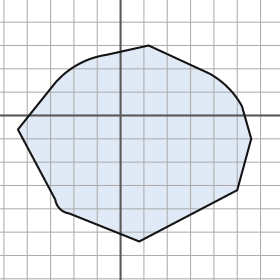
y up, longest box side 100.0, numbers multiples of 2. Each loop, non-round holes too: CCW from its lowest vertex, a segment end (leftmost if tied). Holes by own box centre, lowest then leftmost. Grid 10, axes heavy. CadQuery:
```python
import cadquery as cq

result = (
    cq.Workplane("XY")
    .moveTo(8.0, -54.0)
    .lineTo(50.0, -32.0)
    .lineTo(56.0, -10.0)
    .lineTo(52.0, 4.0)
    .threePointArc((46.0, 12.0), (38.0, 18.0))
    .lineTo(12.0, 30.0)
    .lineTo(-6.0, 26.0)
    .threePointArc((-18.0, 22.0), (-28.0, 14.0))
    .lineTo(-44.0, -6.0)
    .lineTo(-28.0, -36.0)
    .threePointArc((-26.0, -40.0), (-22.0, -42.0))
    .close()
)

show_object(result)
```